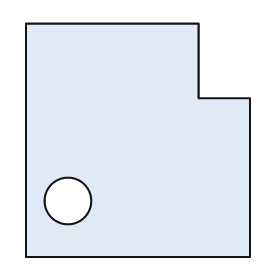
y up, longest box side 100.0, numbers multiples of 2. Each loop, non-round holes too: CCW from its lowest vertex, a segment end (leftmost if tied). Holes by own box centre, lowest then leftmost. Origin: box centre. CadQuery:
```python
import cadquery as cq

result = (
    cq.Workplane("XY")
    .moveTo(-48.0, -50.0)
    .lineTo(48.0, -50.0)
    .lineTo(48.0, 18.0)
    .lineTo(26.0, 18.0)
    .lineTo(26.0, 50.0)
    .lineTo(-48.0, 50.0)
    .close()
    .moveTo(-30.0, -26.0)
    .circle(10.0)
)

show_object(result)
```